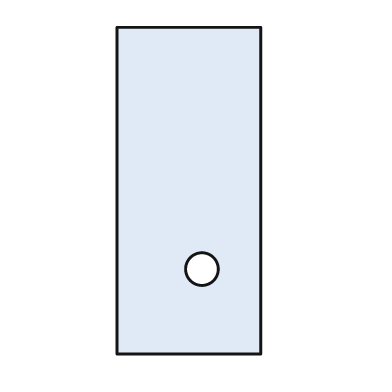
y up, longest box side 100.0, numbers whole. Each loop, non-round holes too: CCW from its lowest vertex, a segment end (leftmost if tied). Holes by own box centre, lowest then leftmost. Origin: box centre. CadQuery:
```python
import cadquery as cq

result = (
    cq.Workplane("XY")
    .moveTo(-22.0, -50.0)
    .lineTo(22.0, -50.0)
    .lineTo(22.0, 50.0)
    .lineTo(-22.0, 50.0)
    .close()
    .moveTo(4.0, -24.0)
    .circle(5.0)
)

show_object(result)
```